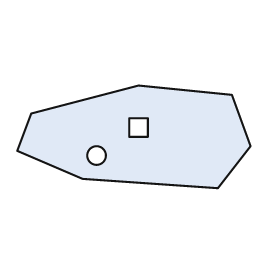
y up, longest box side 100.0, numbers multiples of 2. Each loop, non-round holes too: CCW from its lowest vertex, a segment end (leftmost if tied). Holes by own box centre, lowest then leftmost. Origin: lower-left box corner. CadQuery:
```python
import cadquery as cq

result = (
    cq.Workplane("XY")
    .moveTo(86.0, 0.0)
    .lineTo(100.0, 18.0)
    .lineTo(92.0, 40.0)
    .lineTo(52.0, 44.0)
    .lineTo(6.0, 32.0)
    .lineTo(0.0, 16.0)
    .lineTo(28.0, 4.0)
    .close()
    .moveTo(34.0, 14.0)
    .circle(4.0)
    .moveTo(48.0, 22.0)
    .lineTo(56.0, 22.0)
    .lineTo(56.0, 30.0)
    .lineTo(48.0, 30.0)
    .close()
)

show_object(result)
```